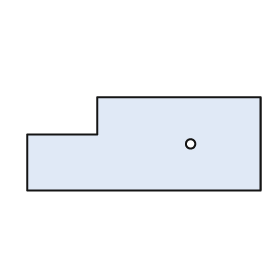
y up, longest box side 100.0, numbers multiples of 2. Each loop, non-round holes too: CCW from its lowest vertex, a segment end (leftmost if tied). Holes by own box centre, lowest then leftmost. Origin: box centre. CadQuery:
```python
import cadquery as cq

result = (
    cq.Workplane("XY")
    .moveTo(-50.0, -20.0)
    .lineTo(50.0, -20.0)
    .lineTo(50.0, 20.0)
    .lineTo(-20.0, 20.0)
    .lineTo(-20.0, 4.0)
    .lineTo(-50.0, 4.0)
    .close()
    .moveTo(20.0, 0.0)
    .circle(2.0)
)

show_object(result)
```